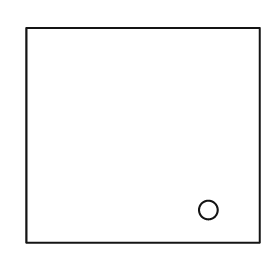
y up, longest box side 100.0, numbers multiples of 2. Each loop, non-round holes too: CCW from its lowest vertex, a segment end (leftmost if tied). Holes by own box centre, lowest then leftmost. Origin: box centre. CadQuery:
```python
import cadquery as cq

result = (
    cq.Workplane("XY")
    .moveTo(-50.0, -46.0)
    .lineTo(50.0, -46.0)
    .lineTo(50.0, 46.0)
    .lineTo(-50.0, 46.0)
    .close()
    .moveTo(28.0, -32.0)
    .circle(4.0)
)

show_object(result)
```